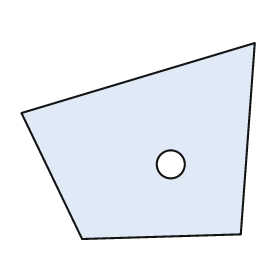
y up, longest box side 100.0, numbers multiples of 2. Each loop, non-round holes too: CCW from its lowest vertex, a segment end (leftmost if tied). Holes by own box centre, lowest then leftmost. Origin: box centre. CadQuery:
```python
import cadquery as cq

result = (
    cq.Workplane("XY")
    .moveTo(-24.0, -42.0)
    .lineTo(44.0, -40.0)
    .lineTo(50.0, 42.0)
    .lineTo(-50.0, 12.0)
    .close()
    .moveTo(14.0, -10.0)
    .circle(6.0)
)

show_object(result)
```